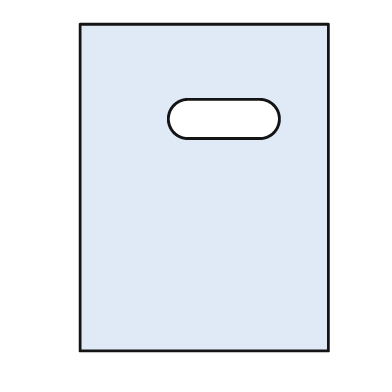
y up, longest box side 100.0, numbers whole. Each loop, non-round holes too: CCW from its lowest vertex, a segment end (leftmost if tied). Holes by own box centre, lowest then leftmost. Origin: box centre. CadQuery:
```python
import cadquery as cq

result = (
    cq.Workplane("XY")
    .moveTo(-38.0, -50.0)
    .lineTo(38.0, -50.0)
    .lineTo(38.0, 50.0)
    .lineTo(-38.0, 50.0)
    .close()
    .moveTo(-5.0, 15.0)
    .lineTo(17.0, 15.0)
    .threePointArc((23.0, 21.0), (17.0, 27.0))
    .lineTo(-5.0, 27.0)
    .threePointArc((-11.0, 21.0), (-5.0, 15.0))
    .close()
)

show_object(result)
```